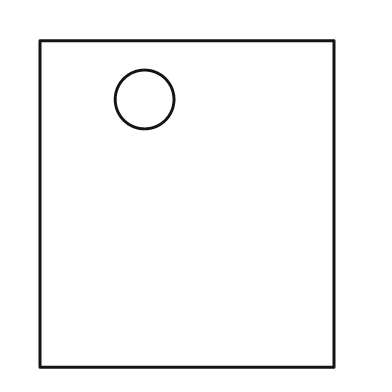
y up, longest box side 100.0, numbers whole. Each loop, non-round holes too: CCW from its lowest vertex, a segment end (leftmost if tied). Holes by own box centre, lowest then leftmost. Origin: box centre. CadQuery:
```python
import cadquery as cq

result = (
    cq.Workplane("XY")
    .moveTo(-45.0, -50.0)
    .lineTo(45.0, -50.0)
    .lineTo(45.0, 50.0)
    .lineTo(-45.0, 50.0)
    .close()
    .moveTo(-13.0, 32.0)
    .circle(9.0)
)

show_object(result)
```